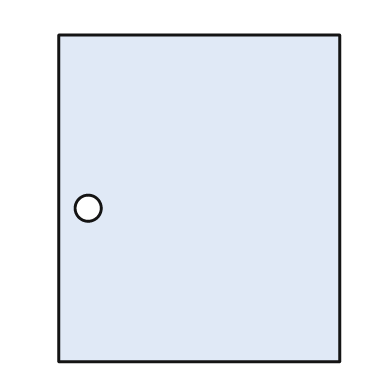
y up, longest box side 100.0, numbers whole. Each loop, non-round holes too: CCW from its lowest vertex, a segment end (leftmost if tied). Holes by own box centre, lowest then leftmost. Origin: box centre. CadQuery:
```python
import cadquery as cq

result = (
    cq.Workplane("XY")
    .moveTo(-43.0, -50.0)
    .lineTo(43.0, -50.0)
    .lineTo(43.0, 50.0)
    .lineTo(-43.0, 50.0)
    .close()
    .moveTo(-34.0, -3.0)
    .circle(4.0)
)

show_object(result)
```